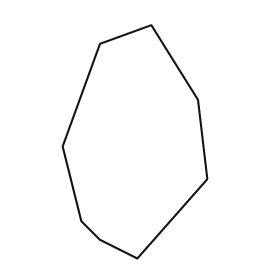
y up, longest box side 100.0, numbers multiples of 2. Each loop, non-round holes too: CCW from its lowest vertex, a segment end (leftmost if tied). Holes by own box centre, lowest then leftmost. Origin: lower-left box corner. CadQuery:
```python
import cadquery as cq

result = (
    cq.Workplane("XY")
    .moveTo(32.0, 0.0)
    .lineTo(62.0, 34.0)
    .lineTo(58.0, 68.0)
    .lineTo(38.0, 100.0)
    .lineTo(16.0, 92.0)
    .lineTo(0.0, 48.0)
    .lineTo(8.0, 16.0)
    .lineTo(16.0, 8.0)
    .close()
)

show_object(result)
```